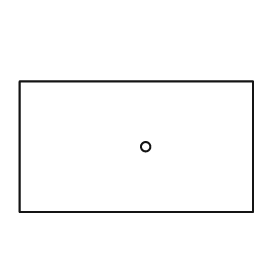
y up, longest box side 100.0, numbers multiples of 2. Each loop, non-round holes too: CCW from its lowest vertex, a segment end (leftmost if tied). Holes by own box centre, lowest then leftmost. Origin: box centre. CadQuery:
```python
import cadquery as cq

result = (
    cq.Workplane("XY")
    .moveTo(-50.0, -28.0)
    .lineTo(50.0, -28.0)
    .lineTo(50.0, 28.0)
    .lineTo(-50.0, 28.0)
    .close()
    .moveTo(4.0, 0.0)
    .circle(2.0)
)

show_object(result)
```